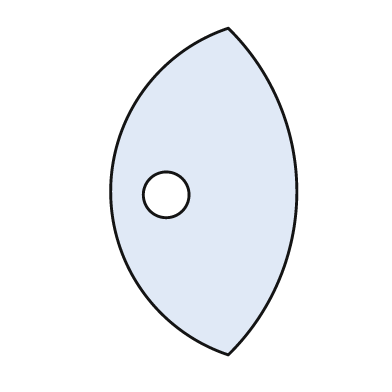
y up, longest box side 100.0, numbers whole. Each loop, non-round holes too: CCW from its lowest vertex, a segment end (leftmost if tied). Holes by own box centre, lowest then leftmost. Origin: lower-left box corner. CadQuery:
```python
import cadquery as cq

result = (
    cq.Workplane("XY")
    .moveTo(36.0, 0.0)
    .threePointArc((57.0, 50.0), (36.0, 100.0))
    .threePointArc((0.0, 50.0), (36.0, 0.0))
    .close()
    .moveTo(17.0, 49.0)
    .circle(7.0)
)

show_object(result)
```